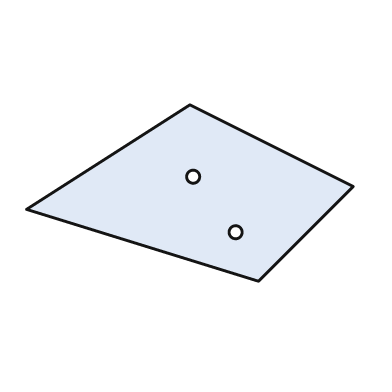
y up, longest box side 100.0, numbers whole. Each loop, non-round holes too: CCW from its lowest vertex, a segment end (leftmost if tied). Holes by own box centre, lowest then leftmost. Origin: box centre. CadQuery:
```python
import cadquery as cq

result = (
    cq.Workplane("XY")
    .moveTo(21.0, -27.0)
    .lineTo(50.0, 2.0)
    .lineTo(0.0, 27.0)
    .lineTo(-50.0, -5.0)
    .close()
    .moveTo(14.0, -12.0)
    .circle(2.0)
    .moveTo(1.0, 5.0)
    .circle(2.0)
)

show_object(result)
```